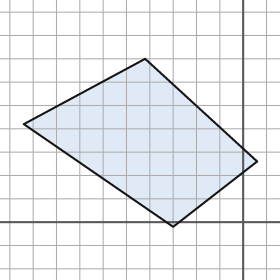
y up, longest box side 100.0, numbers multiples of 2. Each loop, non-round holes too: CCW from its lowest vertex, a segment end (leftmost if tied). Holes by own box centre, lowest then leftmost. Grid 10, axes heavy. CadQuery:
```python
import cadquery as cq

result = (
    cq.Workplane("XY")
    .moveTo(-30.0, -2.0)
    .lineTo(6.0, 26.0)
    .lineTo(-42.0, 70.0)
    .lineTo(-94.0, 42.0)
    .close()
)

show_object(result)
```